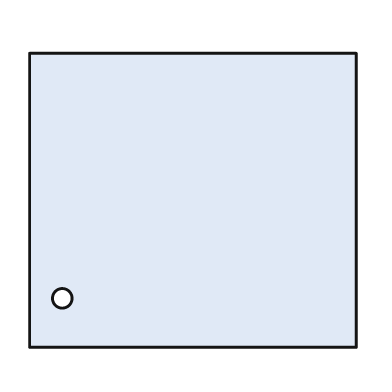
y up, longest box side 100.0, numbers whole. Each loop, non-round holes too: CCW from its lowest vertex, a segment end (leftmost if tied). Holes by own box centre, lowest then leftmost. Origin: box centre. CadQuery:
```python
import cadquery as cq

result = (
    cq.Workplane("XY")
    .moveTo(-50.0, -45.0)
    .lineTo(50.0, -45.0)
    .lineTo(50.0, 45.0)
    .lineTo(-50.0, 45.0)
    .close()
    .moveTo(-40.0, -30.0)
    .circle(3.0)
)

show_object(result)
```